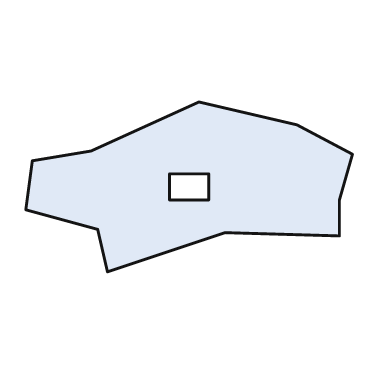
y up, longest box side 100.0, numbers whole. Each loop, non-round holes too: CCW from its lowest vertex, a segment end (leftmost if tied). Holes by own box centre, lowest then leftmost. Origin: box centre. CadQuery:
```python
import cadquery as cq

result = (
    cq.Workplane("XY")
    .moveTo(-25.0, -26.0)
    .lineTo(11.0, -14.0)
    .lineTo(46.0, -15.0)
    .lineTo(46.0, -4.0)
    .lineTo(50.0, 10.0)
    .lineTo(33.0, 19.0)
    .lineTo(3.0, 26.0)
    .lineTo(-30.0, 11.0)
    .lineTo(-48.0, 8.0)
    .lineTo(-50.0, -7.0)
    .lineTo(-28.0, -13.0)
    .close()
    .moveTo(-6.0, -4.0)
    .lineTo(6.0, -4.0)
    .lineTo(6.0, 4.0)
    .lineTo(-6.0, 4.0)
    .close()
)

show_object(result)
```